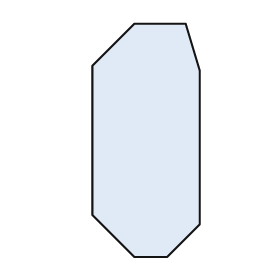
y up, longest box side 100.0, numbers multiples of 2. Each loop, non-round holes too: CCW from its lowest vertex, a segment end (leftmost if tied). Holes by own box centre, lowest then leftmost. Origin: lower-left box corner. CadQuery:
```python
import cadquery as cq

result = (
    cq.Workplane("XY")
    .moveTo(18.0, 0.0)
    .lineTo(32.0, 0.0)
    .lineTo(46.0, 14.0)
    .lineTo(46.0, 80.0)
    .lineTo(40.0, 100.0)
    .lineTo(18.0, 100.0)
    .lineTo(0.0, 82.0)
    .lineTo(0.0, 18.0)
    .close()
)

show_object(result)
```